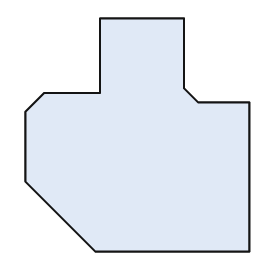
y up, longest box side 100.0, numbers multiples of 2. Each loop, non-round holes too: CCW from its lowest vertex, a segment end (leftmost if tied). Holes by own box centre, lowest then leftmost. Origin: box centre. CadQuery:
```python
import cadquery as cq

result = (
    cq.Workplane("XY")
    .moveTo(-18.0, -50.0)
    .lineTo(48.0, -50.0)
    .lineTo(48.0, 14.0)
    .lineTo(26.0, 14.0)
    .lineTo(20.0, 20.0)
    .lineTo(20.0, 50.0)
    .lineTo(-16.0, 50.0)
    .lineTo(-16.0, 18.0)
    .lineTo(-40.0, 18.0)
    .lineTo(-48.0, 10.0)
    .lineTo(-48.0, -20.0)
    .close()
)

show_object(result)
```